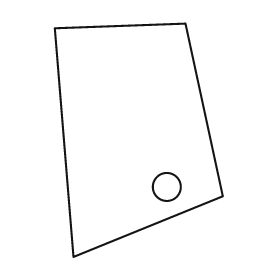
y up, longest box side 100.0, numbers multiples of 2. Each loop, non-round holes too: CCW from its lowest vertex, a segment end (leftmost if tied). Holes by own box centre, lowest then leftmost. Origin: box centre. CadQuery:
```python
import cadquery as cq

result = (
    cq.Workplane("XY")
    .moveTo(-28.0, -50.0)
    .lineTo(36.0, -24.0)
    .lineTo(20.0, 50.0)
    .lineTo(-36.0, 48.0)
    .close()
    .moveTo(12.0, -20.0)
    .circle(6.0)
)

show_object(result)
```